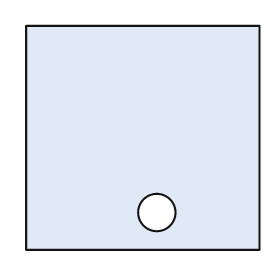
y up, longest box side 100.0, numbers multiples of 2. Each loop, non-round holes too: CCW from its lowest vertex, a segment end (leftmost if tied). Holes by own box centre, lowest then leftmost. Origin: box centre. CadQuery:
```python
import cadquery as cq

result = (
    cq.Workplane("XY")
    .moveTo(-50.0, -48.0)
    .lineTo(50.0, -48.0)
    .lineTo(50.0, 48.0)
    .lineTo(-50.0, 48.0)
    .close()
    .moveTo(6.0, -32.0)
    .circle(8.0)
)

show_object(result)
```